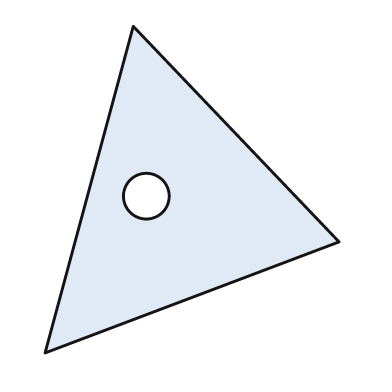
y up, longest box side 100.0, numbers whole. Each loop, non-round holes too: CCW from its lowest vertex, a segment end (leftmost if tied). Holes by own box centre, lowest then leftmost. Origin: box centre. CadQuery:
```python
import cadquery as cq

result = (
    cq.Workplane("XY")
    .moveTo(-45.0, -50.0)
    .lineTo(45.0, -16.0)
    .lineTo(-18.0, 50.0)
    .close()
    .moveTo(-14.0, -2.0)
    .circle(7.0)
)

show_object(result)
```